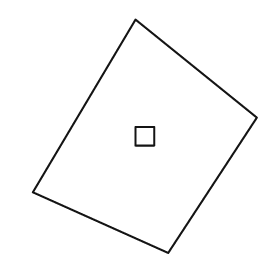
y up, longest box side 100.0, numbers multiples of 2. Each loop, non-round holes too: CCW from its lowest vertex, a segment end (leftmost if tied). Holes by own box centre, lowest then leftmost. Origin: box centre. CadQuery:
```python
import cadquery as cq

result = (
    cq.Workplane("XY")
    .moveTo(10.0, -50.0)
    .lineTo(48.0, 8.0)
    .lineTo(-4.0, 50.0)
    .lineTo(-48.0, -24.0)
    .close()
    .moveTo(-4.0, -4.0)
    .lineTo(4.0, -4.0)
    .lineTo(4.0, 4.0)
    .lineTo(-4.0, 4.0)
    .close()
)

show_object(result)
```